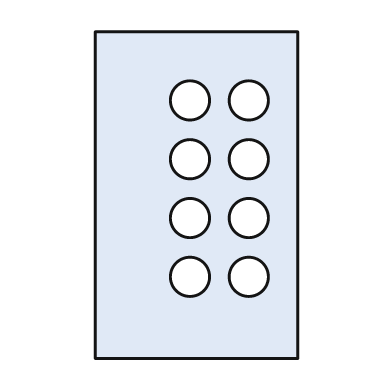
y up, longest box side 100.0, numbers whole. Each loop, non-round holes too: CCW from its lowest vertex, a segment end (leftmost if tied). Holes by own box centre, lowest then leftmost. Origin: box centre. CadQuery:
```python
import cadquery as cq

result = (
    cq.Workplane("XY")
    .moveTo(-31.0, -50.0)
    .lineTo(31.0, -50.0)
    .lineTo(31.0, 50.0)
    .lineTo(-31.0, 50.0)
    .close()
    .moveTo(-2.0, -25.0)
    .circle(6.0)
    .moveTo(16.0, -25.0)
    .circle(6.0)
    .moveTo(-2.0, -7.0)
    .circle(6.0)
    .moveTo(16.0, -7.0)
    .circle(6.0)
    .moveTo(-2.0, 11.0)
    .circle(6.0)
    .moveTo(16.0, 11.0)
    .circle(6.0)
    .moveTo(-2.0, 29.0)
    .circle(6.0)
    .moveTo(16.0, 29.0)
    .circle(6.0)
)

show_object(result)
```